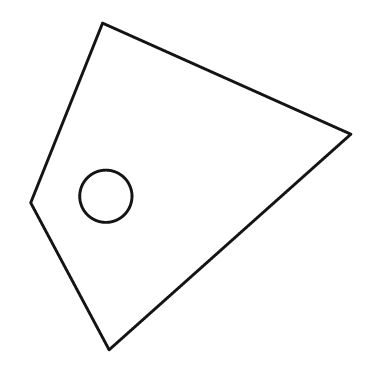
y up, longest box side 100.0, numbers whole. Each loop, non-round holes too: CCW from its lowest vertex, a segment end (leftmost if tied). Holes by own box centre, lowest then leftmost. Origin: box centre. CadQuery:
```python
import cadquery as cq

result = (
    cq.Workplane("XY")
    .moveTo(-25.0, -50.0)
    .lineTo(49.0, 16.0)
    .lineTo(-27.0, 50.0)
    .lineTo(-49.0, -5.0)
    .close()
    .moveTo(-26.0, -3.0)
    .circle(8.0)
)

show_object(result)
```